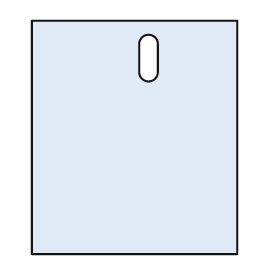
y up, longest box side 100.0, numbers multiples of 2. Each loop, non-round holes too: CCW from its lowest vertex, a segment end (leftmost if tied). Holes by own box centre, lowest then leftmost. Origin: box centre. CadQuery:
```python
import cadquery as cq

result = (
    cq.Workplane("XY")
    .moveTo(-44.0, -50.0)
    .lineTo(44.0, -50.0)
    .lineTo(44.0, 50.0)
    .lineTo(-44.0, 50.0)
    .close()
    .moveTo(2.0, 28.0)
    .threePointArc((6.0, 24.0), (10.0, 28.0))
    .lineTo(10.0, 40.0)
    .threePointArc((6.0, 44.0), (2.0, 40.0))
    .close()
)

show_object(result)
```